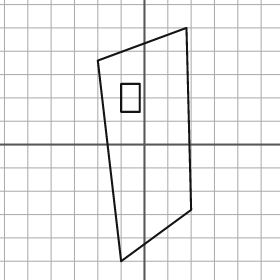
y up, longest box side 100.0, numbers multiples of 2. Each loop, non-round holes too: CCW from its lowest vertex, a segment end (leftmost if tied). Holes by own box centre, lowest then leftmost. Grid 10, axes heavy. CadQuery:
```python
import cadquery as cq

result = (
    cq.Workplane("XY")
    .moveTo(-10.0, -50.0)
    .lineTo(20.0, -28.0)
    .lineTo(18.0, 50.0)
    .lineTo(-20.0, 36.0)
    .close()
    .moveTo(-10.0, 14.0)
    .lineTo(-2.0, 14.0)
    .lineTo(-2.0, 26.0)
    .lineTo(-10.0, 26.0)
    .close()
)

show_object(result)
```